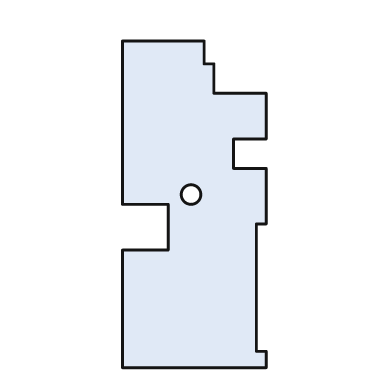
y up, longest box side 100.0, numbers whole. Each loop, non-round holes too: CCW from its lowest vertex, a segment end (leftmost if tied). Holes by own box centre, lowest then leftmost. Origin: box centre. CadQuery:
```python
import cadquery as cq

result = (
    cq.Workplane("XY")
    .moveTo(-22.0, -50.0)
    .lineTo(22.0, -50.0)
    .lineTo(22.0, -45.0)
    .lineTo(19.0, -45.0)
    .lineTo(19.0, -6.0)
    .lineTo(22.0, -6.0)
    .lineTo(22.0, 11.0)
    .lineTo(12.0, 11.0)
    .lineTo(12.0, 20.0)
    .lineTo(22.0, 20.0)
    .lineTo(22.0, 34.0)
    .lineTo(6.0, 34.0)
    .lineTo(6.0, 43.0)
    .lineTo(3.0, 43.0)
    .lineTo(3.0, 50.0)
    .lineTo(-22.0, 50.0)
    .lineTo(-22.0, 0.0)
    .lineTo(-8.0, 0.0)
    .lineTo(-8.0, -14.0)
    .lineTo(-22.0, -14.0)
    .close()
    .moveTo(-1.0, 3.0)
    .circle(3.0)
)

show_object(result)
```